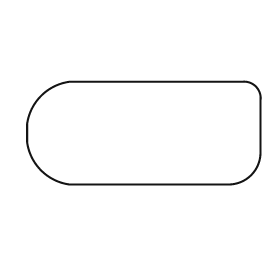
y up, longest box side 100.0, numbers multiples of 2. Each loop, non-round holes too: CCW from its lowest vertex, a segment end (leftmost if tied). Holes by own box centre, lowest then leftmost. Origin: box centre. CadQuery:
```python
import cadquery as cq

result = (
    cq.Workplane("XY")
    .moveTo(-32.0, -22.0)
    .lineTo(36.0, -22.0)
    .threePointArc((46.0, -18.0), (50.0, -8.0))
    .lineTo(50.0, 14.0)
    .threePointArc((48.0, 20.0), (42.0, 22.0))
    .lineTo(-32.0, 22.0)
    .threePointArc((-44.0, 16.0), (-50.0, 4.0))
    .lineTo(-50.0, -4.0)
    .threePointArc((-44.0, -16.0), (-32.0, -22.0))
    .close()
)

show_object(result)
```